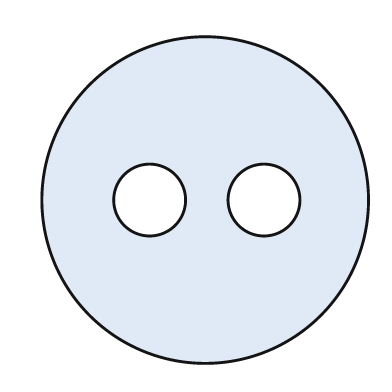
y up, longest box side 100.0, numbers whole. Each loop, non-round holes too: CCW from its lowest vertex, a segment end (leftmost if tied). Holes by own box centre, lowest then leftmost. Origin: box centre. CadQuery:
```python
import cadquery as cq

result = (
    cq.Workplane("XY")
    .moveTo(0.0, 0.0)
    .circle(50.0)
    .moveTo(-17.0, 0.0)
    .circle(11.0)
    .moveTo(18.0, 0.0)
    .circle(11.0)
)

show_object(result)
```